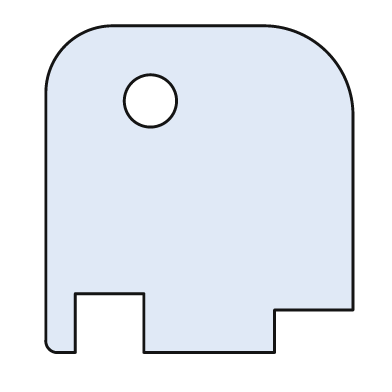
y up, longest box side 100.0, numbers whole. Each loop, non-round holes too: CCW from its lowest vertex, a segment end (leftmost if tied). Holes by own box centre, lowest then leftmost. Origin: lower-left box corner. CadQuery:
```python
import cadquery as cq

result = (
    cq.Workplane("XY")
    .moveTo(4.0, 0.0)
    .lineTo(9.0, 0.0)
    .lineTo(9.0, 18.0)
    .lineTo(30.0, 18.0)
    .lineTo(30.0, 0.0)
    .lineTo(70.0, 0.0)
    .lineTo(70.0, 13.0)
    .lineTo(94.0, 13.0)
    .lineTo(94.0, 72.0)
    .threePointArc((86.0, 92.0), (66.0, 100.0))
    .lineTo(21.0, 100.0)
    .threePointArc((6.0, 94.0), (0.0, 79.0))
    .lineTo(0.0, 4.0)
    .threePointArc((1.0, 1.0), (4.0, 0.0))
    .close()
    .moveTo(32.0, 77.0)
    .circle(8.0)
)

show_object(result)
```